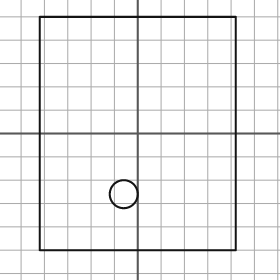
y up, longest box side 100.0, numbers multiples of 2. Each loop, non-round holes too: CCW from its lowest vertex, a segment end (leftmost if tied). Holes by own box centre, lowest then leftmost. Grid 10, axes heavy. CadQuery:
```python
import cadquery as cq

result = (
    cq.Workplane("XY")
    .moveTo(-42.0, -50.0)
    .lineTo(42.0, -50.0)
    .lineTo(42.0, 50.0)
    .lineTo(-42.0, 50.0)
    .close()
    .moveTo(-6.0, -26.0)
    .circle(6.0)
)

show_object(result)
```